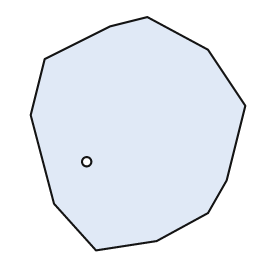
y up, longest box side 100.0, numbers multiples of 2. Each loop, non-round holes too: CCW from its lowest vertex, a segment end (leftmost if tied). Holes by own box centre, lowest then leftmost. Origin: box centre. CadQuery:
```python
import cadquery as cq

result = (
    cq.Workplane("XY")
    .moveTo(-18.0, -50.0)
    .lineTo(8.0, -46.0)
    .lineTo(30.0, -34.0)
    .lineTo(38.0, -20.0)
    .lineTo(46.0, 12.0)
    .lineTo(30.0, 36.0)
    .lineTo(4.0, 50.0)
    .lineTo(-12.0, 46.0)
    .lineTo(-40.0, 32.0)
    .lineTo(-46.0, 8.0)
    .lineTo(-36.0, -30.0)
    .close()
    .moveTo(-22.0, -12.0)
    .circle(2.0)
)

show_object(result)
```